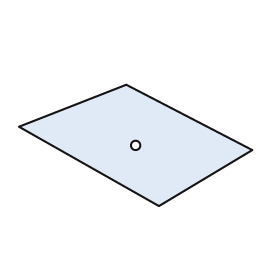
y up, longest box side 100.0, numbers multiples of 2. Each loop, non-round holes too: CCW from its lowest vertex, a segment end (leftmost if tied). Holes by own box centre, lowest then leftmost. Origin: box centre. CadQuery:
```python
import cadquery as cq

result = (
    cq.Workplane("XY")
    .moveTo(10.0, -26.0)
    .lineTo(50.0, -2.0)
    .lineTo(-4.0, 26.0)
    .lineTo(-50.0, 8.0)
    .close()
    .moveTo(0.0, 0.0)
    .circle(2.0)
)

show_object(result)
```